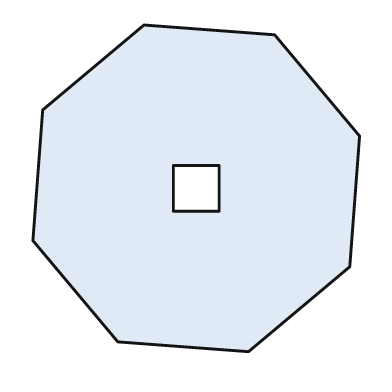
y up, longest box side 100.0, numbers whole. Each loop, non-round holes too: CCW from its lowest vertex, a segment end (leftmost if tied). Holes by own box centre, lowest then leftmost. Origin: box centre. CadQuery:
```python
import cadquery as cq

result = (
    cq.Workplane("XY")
    .moveTo(16.0, -50.0)
    .lineTo(47.0, -24.0)
    .lineTo(50.0, 16.0)
    .lineTo(24.0, 47.0)
    .lineTo(-16.0, 50.0)
    .lineTo(-47.0, 24.0)
    .lineTo(-50.0, -16.0)
    .lineTo(-24.0, -47.0)
    .close()
    .moveTo(-7.0, -7.0)
    .lineTo(7.0, -7.0)
    .lineTo(7.0, 7.0)
    .lineTo(-7.0, 7.0)
    .close()
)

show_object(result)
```